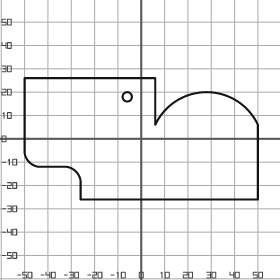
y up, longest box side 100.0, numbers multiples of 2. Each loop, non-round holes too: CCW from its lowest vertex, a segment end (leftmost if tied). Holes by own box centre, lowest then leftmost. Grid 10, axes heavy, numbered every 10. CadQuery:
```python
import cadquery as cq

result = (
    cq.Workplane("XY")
    .moveTo(-26.0, -26.0)
    .lineTo(50.0, -26.0)
    .lineTo(50.0, 6.0)
    .threePointArc((28.0, 20.0), (6.0, 6.0))
    .lineTo(6.0, 26.0)
    .lineTo(-50.0, 26.0)
    .lineTo(-50.0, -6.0)
    .threePointArc((-48.0, -10.0), (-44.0, -12.0))
    .lineTo(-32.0, -12.0)
    .threePointArc((-28.0, -14.0), (-26.0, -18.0))
    .close()
    .moveTo(-6.0, 18.0)
    .circle(2.0)
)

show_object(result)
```